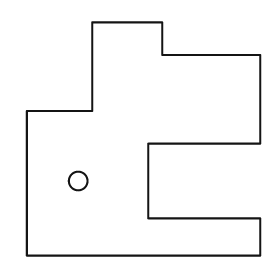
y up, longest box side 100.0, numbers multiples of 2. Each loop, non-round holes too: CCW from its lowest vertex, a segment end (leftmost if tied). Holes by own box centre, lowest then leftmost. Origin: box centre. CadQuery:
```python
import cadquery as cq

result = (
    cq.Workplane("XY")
    .moveTo(-50.0, -50.0)
    .lineTo(50.0, -50.0)
    .lineTo(50.0, -34.0)
    .lineTo(2.0, -34.0)
    .lineTo(2.0, -2.0)
    .lineTo(50.0, -2.0)
    .lineTo(50.0, 36.0)
    .lineTo(8.0, 36.0)
    .lineTo(8.0, 50.0)
    .lineTo(-22.0, 50.0)
    .lineTo(-22.0, 12.0)
    .lineTo(-50.0, 12.0)
    .close()
    .moveTo(-28.0, -18.0)
    .circle(4.0)
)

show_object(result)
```